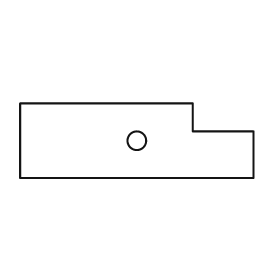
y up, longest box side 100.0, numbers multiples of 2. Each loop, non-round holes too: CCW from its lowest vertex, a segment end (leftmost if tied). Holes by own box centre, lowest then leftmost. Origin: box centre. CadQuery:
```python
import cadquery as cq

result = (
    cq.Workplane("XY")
    .moveTo(-50.0, -16.0)
    .lineTo(50.0, -16.0)
    .lineTo(50.0, 4.0)
    .lineTo(24.0, 4.0)
    .lineTo(24.0, 16.0)
    .lineTo(-50.0, 16.0)
    .close()
    .moveTo(0.0, 0.0)
    .circle(4.0)
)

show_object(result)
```